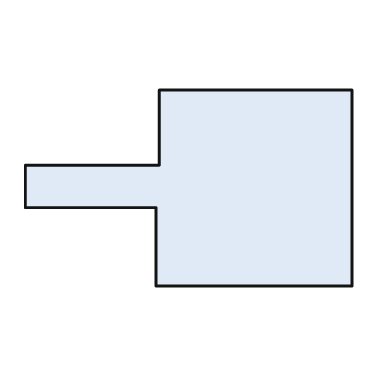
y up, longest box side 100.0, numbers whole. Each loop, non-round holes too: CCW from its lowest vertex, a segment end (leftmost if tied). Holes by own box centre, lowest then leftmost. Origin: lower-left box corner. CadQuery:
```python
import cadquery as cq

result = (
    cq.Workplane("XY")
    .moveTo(40.0, 0.0)
    .lineTo(100.0, 0.0)
    .lineTo(100.0, 60.0)
    .lineTo(41.0, 60.0)
    .lineTo(41.0, 37.0)
    .lineTo(0.0, 37.0)
    .lineTo(0.0, 24.0)
    .lineTo(40.0, 24.0)
    .close()
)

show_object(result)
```